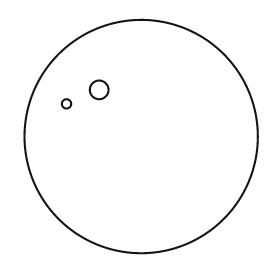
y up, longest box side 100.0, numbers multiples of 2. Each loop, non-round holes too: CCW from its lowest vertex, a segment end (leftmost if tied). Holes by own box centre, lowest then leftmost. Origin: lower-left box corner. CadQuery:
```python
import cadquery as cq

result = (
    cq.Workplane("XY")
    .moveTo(50.0, 50.0)
    .circle(50.0)
    .moveTo(18.0, 64.0)
    .circle(2.0)
    .moveTo(32.0, 70.0)
    .circle(4.0)
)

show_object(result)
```